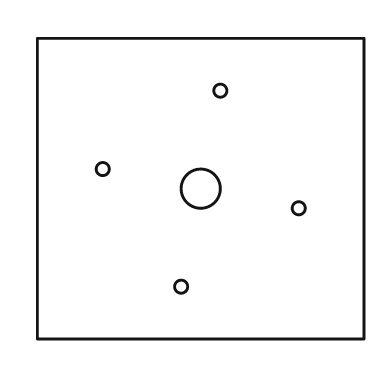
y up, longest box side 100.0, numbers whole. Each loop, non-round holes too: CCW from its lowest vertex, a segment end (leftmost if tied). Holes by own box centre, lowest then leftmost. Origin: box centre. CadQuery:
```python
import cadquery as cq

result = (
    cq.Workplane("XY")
    .moveTo(-50.0, -46.0)
    .lineTo(50.0, -46.0)
    .lineTo(50.0, 46.0)
    .lineTo(-50.0, 46.0)
    .close()
    .moveTo(-6.0, -30.0)
    .circle(2.0)
    .moveTo(30.0, -6.0)
    .circle(2.0)
    .moveTo(0.0, 0.0)
    .circle(6.0)
    .moveTo(-30.0, 6.0)
    .circle(2.0)
    .moveTo(6.0, 30.0)
    .circle(2.0)
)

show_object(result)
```